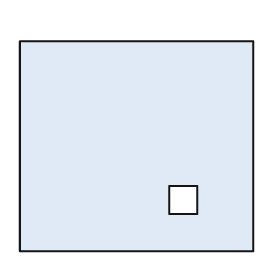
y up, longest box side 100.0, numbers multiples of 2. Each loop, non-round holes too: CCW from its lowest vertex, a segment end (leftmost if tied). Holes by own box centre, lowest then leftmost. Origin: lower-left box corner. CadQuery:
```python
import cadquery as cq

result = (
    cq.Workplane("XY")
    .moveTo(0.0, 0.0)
    .lineTo(100.0, 0.0)
    .lineTo(100.0, 90.0)
    .lineTo(0.0, 90.0)
    .close()
    .moveTo(64.0, 16.0)
    .lineTo(76.0, 16.0)
    .lineTo(76.0, 28.0)
    .lineTo(64.0, 28.0)
    .close()
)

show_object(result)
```